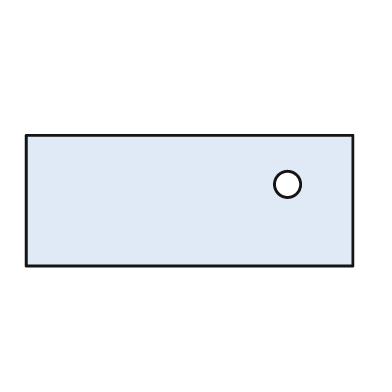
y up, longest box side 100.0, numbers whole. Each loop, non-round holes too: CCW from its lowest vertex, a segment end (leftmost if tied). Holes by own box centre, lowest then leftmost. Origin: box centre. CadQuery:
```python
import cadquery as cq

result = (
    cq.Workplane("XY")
    .moveTo(-50.0, -20.0)
    .lineTo(50.0, -20.0)
    .lineTo(50.0, 20.0)
    .lineTo(-50.0, 20.0)
    .close()
    .moveTo(30.0, 5.0)
    .circle(4.0)
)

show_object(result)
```